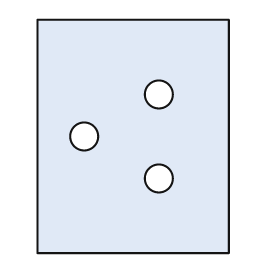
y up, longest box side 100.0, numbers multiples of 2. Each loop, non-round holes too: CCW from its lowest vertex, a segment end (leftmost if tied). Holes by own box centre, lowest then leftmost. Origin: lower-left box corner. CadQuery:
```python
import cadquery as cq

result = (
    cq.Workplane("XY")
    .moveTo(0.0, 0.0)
    .lineTo(82.0, 0.0)
    .lineTo(82.0, 100.0)
    .lineTo(0.0, 100.0)
    .close()
    .moveTo(52.0, 32.0)
    .circle(6.0)
    .moveTo(20.0, 50.0)
    .circle(6.0)
    .moveTo(52.0, 68.0)
    .circle(6.0)
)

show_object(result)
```